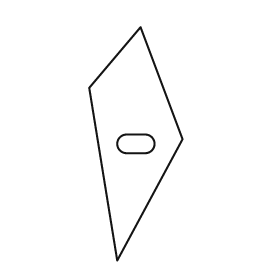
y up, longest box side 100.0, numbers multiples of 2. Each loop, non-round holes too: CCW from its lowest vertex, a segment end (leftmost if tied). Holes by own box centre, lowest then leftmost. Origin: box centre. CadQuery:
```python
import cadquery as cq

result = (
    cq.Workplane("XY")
    .moveTo(-8.0, -50.0)
    .lineTo(20.0, 2.0)
    .lineTo(2.0, 50.0)
    .lineTo(-20.0, 24.0)
    .close()
    .moveTo(-4.0, -4.0)
    .lineTo(4.0, -4.0)
    .threePointArc((8.0, 0.0), (4.0, 4.0))
    .lineTo(-4.0, 4.0)
    .threePointArc((-8.0, 0.0), (-4.0, -4.0))
    .close()
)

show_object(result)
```